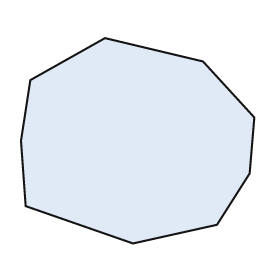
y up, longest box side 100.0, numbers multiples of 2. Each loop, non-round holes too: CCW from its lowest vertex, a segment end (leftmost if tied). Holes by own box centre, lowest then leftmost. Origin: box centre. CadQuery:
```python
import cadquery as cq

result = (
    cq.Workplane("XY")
    .moveTo(-2.0, -44.0)
    .lineTo(34.0, -36.0)
    .lineTo(48.0, -14.0)
    .lineTo(50.0, 10.0)
    .lineTo(28.0, 34.0)
    .lineTo(-14.0, 44.0)
    .lineTo(-46.0, 26.0)
    .lineTo(-50.0, 0.0)
    .lineTo(-48.0, -28.0)
    .close()
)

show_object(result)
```